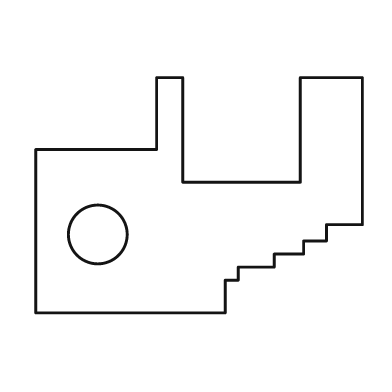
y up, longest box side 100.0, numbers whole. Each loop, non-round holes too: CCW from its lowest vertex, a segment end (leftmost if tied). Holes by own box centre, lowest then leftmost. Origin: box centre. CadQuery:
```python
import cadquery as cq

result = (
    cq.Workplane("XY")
    .moveTo(-50.0, -36.0)
    .lineTo(8.0, -36.0)
    .lineTo(8.0, -26.0)
    .lineTo(12.0, -26.0)
    .lineTo(12.0, -22.0)
    .lineTo(23.0, -22.0)
    .lineTo(23.0, -18.0)
    .lineTo(32.0, -18.0)
    .lineTo(32.0, -14.0)
    .lineTo(39.0, -14.0)
    .lineTo(39.0, -9.0)
    .lineTo(50.0, -9.0)
    .lineTo(50.0, 36.0)
    .lineTo(31.0, 36.0)
    .lineTo(31.0, 4.0)
    .lineTo(-5.0, 4.0)
    .lineTo(-5.0, 36.0)
    .lineTo(-13.0, 36.0)
    .lineTo(-13.0, 14.0)
    .lineTo(-50.0, 14.0)
    .close()
    .moveTo(-31.0, -12.0)
    .circle(9.0)
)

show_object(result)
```